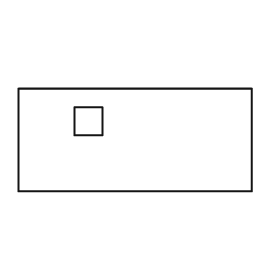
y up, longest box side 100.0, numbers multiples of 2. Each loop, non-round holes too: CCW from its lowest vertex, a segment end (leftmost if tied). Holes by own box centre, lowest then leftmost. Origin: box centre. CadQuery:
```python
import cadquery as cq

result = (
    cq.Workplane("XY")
    .moveTo(-50.0, -22.0)
    .lineTo(50.0, -22.0)
    .lineTo(50.0, 22.0)
    .lineTo(-50.0, 22.0)
    .close()
    .moveTo(-26.0, 2.0)
    .lineTo(-14.0, 2.0)
    .lineTo(-14.0, 14.0)
    .lineTo(-26.0, 14.0)
    .close()
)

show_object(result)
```